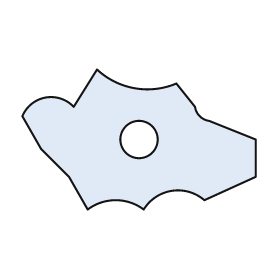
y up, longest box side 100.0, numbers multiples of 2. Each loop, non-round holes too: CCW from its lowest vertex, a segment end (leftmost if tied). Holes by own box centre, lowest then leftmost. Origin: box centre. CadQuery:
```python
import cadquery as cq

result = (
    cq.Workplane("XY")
    .moveTo(-22.0, -30.0)
    .threePointArc((-10.0, -26.0), (2.0, -30.0))
    .threePointArc((14.0, -22.0), (28.0, -26.0))
    .lineTo(50.0, -16.0)
    .lineTo(50.0, 0.0)
    .lineTo(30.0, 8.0)
    .threePointArc((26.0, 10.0), (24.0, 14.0))
    .lineTo(16.0, 24.0)
    .threePointArc((-2.0, 22.0), (-18.0, 30.0))
    .lineTo(-28.0, 14.0)
    .threePointArc((-40.0, 18.0), (-50.0, 10.0))
    .lineTo(-42.0, -4.0)
    .lineTo(-30.0, -16.0)
    .close()
    .moveTo(0.0, 0.0)
    .circle(8.0)
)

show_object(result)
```